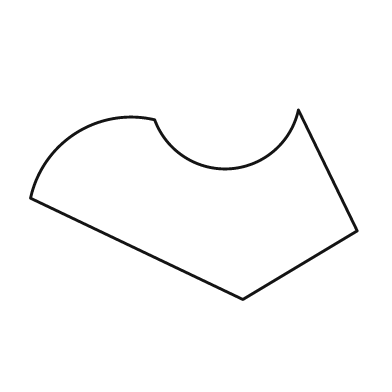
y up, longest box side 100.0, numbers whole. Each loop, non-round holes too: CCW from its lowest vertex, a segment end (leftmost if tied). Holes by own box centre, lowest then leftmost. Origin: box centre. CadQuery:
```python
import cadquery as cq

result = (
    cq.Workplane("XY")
    .moveTo(15.0, -29.0)
    .lineTo(50.0, -8.0)
    .lineTo(32.0, 29.0)
    .threePointArc((11.0, 11.0), (-12.0, 26.0))
    .threePointArc((-36.0, 22.0), (-50.0, 2.0))
    .close()
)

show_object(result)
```